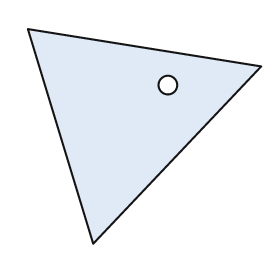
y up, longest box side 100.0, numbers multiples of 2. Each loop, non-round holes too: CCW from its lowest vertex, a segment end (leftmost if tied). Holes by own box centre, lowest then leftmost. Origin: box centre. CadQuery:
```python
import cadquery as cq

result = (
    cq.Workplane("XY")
    .moveTo(-22.0, -46.0)
    .lineTo(50.0, 30.0)
    .lineTo(-50.0, 46.0)
    .close()
    .moveTo(10.0, 22.0)
    .circle(4.0)
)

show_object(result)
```